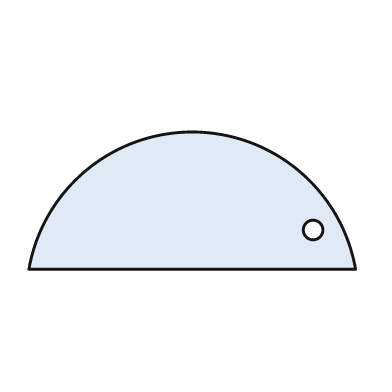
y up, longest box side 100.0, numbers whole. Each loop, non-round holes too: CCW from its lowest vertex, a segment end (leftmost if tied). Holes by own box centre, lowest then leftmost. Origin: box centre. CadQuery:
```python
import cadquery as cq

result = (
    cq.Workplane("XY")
    .moveTo(-50.0, -21.0)
    .lineTo(50.0, -21.0)
    .threePointArc((0.0, 21.0), (-50.0, -21.0))
    .close()
    .moveTo(37.0, -9.0)
    .circle(3.0)
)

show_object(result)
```